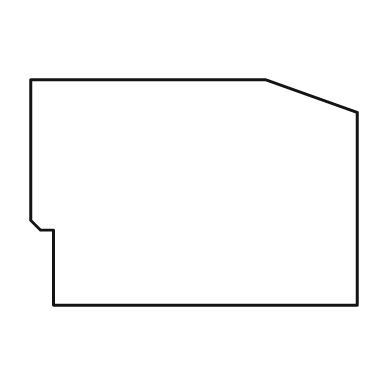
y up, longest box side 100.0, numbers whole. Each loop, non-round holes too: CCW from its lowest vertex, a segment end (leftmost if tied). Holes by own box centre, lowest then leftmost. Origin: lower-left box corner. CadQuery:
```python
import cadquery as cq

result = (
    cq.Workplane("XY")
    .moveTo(7.0, 0.0)
    .lineTo(100.0, 0.0)
    .lineTo(100.0, 59.0)
    .lineTo(72.0, 69.0)
    .lineTo(0.0, 69.0)
    .lineTo(0.0, 26.0)
    .lineTo(3.0, 23.0)
    .lineTo(7.0, 23.0)
    .close()
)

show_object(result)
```